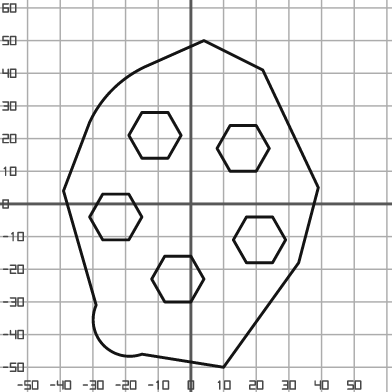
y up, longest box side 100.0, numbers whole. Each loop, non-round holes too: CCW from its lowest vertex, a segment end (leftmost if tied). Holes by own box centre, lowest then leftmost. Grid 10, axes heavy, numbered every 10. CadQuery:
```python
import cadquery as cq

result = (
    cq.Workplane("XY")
    .moveTo(10.0, -50.0)
    .lineTo(33.0, -18.0)
    .lineTo(39.0, 5.0)
    .lineTo(22.0, 41.0)
    .lineTo(4.0, 50.0)
    .lineTo(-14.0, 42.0)
    .threePointArc((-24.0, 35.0), (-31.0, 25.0))
    .lineTo(-39.0, 4.0)
    .lineTo(-29.0, -31.0)
    .threePointArc((-27.0, -43.0), (-15.0, -46.0))
    .close()
    .moveTo(-8.0, -30.0)
    .lineTo(0.0, -30.0)
    .lineTo(4.0, -23.0)
    .lineTo(0.0, -16.0)
    .lineTo(-8.0, -16.0)
    .lineTo(-12.0, -23.0)
    .close()
    .moveTo(17.0, -18.0)
    .lineTo(25.0, -18.0)
    .lineTo(29.0, -11.0)
    .lineTo(25.0, -4.0)
    .lineTo(17.0, -4.0)
    .lineTo(13.0, -11.0)
    .close()
    .moveTo(-27.0, -11.0)
    .lineTo(-19.0, -11.0)
    .lineTo(-15.0, -4.0)
    .lineTo(-19.0, 3.0)
    .lineTo(-27.0, 3.0)
    .lineTo(-31.0, -4.0)
    .close()
    .moveTo(12.0, 10.0)
    .lineTo(20.0, 10.0)
    .lineTo(24.0, 17.0)
    .lineTo(20.0, 24.0)
    .lineTo(12.0, 24.0)
    .lineTo(8.0, 17.0)
    .close()
    .moveTo(-15.0, 14.0)
    .lineTo(-7.0, 14.0)
    .lineTo(-3.0, 21.0)
    .lineTo(-7.0, 28.0)
    .lineTo(-15.0, 28.0)
    .lineTo(-19.0, 21.0)
    .close()
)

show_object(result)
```